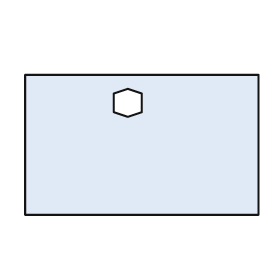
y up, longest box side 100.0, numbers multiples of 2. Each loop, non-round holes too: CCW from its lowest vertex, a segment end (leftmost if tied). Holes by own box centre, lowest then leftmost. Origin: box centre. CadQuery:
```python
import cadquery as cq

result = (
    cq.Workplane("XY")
    .moveTo(-50.0, -30.0)
    .lineTo(50.0, -30.0)
    .lineTo(50.0, 30.0)
    .lineTo(-50.0, 30.0)
    .close()
    .moveTo(-6.0, 12.0)
    .lineTo(0.0, 14.0)
    .lineTo(0.0, 22.0)
    .lineTo(-6.0, 24.0)
    .lineTo(-12.0, 22.0)
    .lineTo(-12.0, 14.0)
    .close()
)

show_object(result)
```